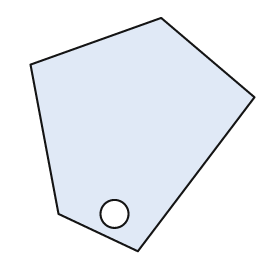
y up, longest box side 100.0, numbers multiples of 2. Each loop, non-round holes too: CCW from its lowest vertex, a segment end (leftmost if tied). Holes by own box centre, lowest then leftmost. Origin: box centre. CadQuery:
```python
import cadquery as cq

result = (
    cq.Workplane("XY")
    .moveTo(-2.0, -50.0)
    .lineTo(48.0, 16.0)
    .lineTo(8.0, 50.0)
    .lineTo(-48.0, 30.0)
    .lineTo(-36.0, -34.0)
    .close()
    .moveTo(-12.0, -34.0)
    .circle(6.0)
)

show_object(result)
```